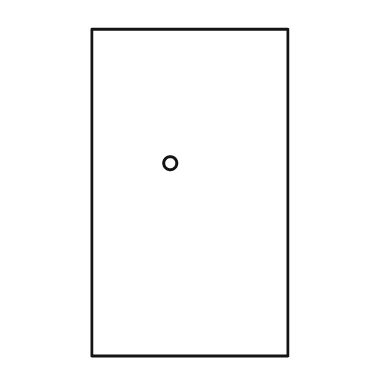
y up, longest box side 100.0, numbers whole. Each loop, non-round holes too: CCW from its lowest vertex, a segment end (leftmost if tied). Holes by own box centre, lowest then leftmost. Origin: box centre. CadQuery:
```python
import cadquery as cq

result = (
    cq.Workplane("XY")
    .moveTo(-30.0, -50.0)
    .lineTo(30.0, -50.0)
    .lineTo(30.0, 50.0)
    .lineTo(-30.0, 50.0)
    .close()
    .moveTo(-6.0, 9.0)
    .circle(2.0)
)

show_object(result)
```